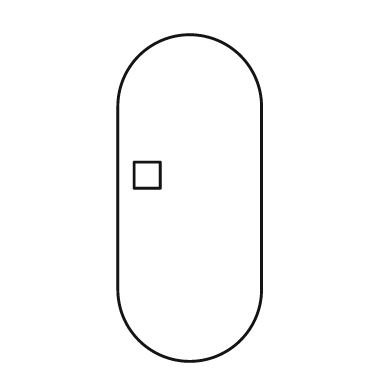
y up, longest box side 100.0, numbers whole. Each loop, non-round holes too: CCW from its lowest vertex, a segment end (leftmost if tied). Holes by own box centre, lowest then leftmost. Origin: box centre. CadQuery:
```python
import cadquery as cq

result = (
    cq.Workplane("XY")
    .moveTo(-22.0, -28.0)
    .threePointArc((0.0, -50.0), (22.0, -28.0))
    .lineTo(22.0, 28.0)
    .threePointArc((0.0, 50.0), (-22.0, 28.0))
    .close()
    .moveTo(-17.0, 3.0)
    .lineTo(-9.0, 3.0)
    .lineTo(-9.0, 11.0)
    .lineTo(-17.0, 11.0)
    .close()
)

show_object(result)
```